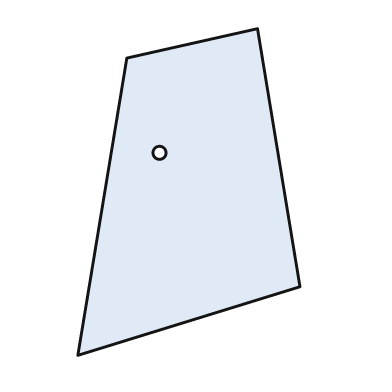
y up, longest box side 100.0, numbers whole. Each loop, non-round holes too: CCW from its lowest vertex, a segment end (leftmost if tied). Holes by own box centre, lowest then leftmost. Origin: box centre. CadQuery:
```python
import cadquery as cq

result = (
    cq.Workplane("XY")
    .moveTo(-34.0, -50.0)
    .lineTo(34.0, -29.0)
    .lineTo(21.0, 50.0)
    .lineTo(-19.0, 41.0)
    .close()
    .moveTo(-9.0, 12.0)
    .circle(2.0)
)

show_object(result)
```